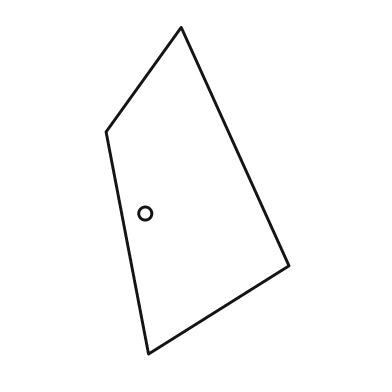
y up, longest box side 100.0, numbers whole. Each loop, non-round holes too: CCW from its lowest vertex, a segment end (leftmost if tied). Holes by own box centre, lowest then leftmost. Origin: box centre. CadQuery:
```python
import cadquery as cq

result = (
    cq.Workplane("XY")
    .moveTo(-15.0, -50.0)
    .lineTo(28.0, -23.0)
    .lineTo(-5.0, 50.0)
    .lineTo(-28.0, 18.0)
    .close()
    .moveTo(-16.0, -7.0)
    .circle(2.0)
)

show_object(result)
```